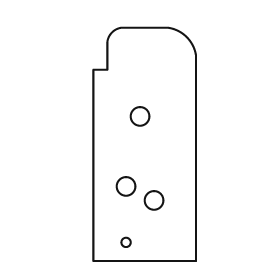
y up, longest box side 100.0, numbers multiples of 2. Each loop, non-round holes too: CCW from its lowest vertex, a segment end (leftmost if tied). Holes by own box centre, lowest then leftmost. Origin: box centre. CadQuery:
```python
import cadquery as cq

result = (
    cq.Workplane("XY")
    .moveTo(-22.0, -50.0)
    .lineTo(22.0, -50.0)
    .lineTo(22.0, 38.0)
    .threePointArc((18.0, 46.0), (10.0, 50.0))
    .lineTo(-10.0, 50.0)
    .threePointArc((-14.0, 48.0), (-16.0, 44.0))
    .lineTo(-16.0, 32.0)
    .lineTo(-22.0, 32.0)
    .close()
    .moveTo(-8.0, -42.0)
    .circle(2.0)
    .moveTo(4.0, -24.0)
    .circle(4.0)
    .moveTo(-8.0, -18.0)
    .circle(4.0)
    .moveTo(-2.0, 12.0)
    .circle(4.0)
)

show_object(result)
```